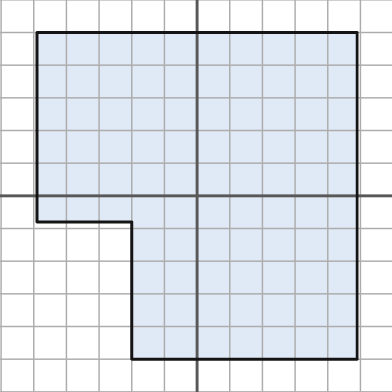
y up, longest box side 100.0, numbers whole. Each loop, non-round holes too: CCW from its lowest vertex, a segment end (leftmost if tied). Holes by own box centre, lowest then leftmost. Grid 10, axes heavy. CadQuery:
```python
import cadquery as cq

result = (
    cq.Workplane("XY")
    .moveTo(-20.0, -50.0)
    .lineTo(49.0, -50.0)
    .lineTo(49.0, 50.0)
    .lineTo(-49.0, 50.0)
    .lineTo(-49.0, -8.0)
    .lineTo(-20.0, -8.0)
    .close()
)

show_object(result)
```